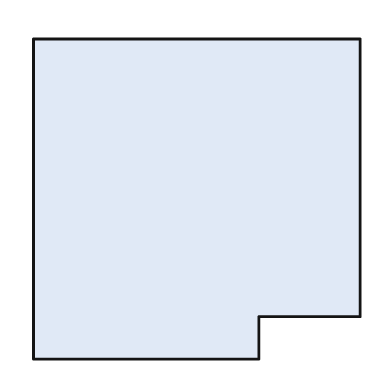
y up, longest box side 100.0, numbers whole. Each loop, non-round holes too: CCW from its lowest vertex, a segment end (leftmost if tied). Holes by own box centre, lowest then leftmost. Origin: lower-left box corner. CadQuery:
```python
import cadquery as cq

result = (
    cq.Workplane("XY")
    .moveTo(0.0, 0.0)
    .lineTo(69.0, 0.0)
    .lineTo(69.0, 13.0)
    .lineTo(100.0, 13.0)
    .lineTo(100.0, 98.0)
    .lineTo(0.0, 98.0)
    .close()
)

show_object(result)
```